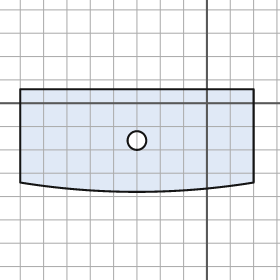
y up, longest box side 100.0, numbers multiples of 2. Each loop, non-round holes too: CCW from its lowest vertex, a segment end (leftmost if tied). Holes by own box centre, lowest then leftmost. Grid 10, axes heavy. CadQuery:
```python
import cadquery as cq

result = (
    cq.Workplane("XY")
    .moveTo(-80.0, -34.0)
    .threePointArc((-30.0, -38.0), (20.0, -34.0))
    .lineTo(20.0, 6.0)
    .lineTo(-80.0, 6.0)
    .close()
    .moveTo(-30.0, -16.0)
    .circle(4.0)
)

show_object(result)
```